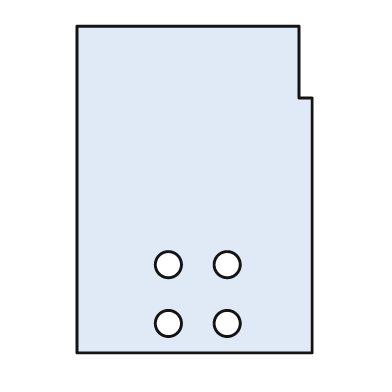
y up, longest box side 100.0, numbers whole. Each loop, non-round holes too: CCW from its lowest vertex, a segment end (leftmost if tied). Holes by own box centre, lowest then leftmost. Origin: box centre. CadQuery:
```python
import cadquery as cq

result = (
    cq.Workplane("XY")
    .moveTo(-36.0, -50.0)
    .lineTo(36.0, -50.0)
    .lineTo(36.0, 28.0)
    .lineTo(32.0, 28.0)
    .lineTo(32.0, 50.0)
    .lineTo(-36.0, 50.0)
    .close()
    .moveTo(-8.0, -41.0)
    .circle(4.0)
    .moveTo(10.0, -41.0)
    .circle(4.0)
    .moveTo(-8.0, -23.0)
    .circle(4.0)
    .moveTo(10.0, -23.0)
    .circle(4.0)
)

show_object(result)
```